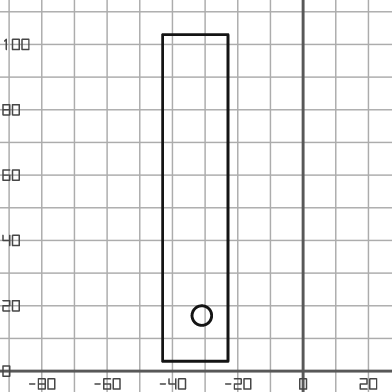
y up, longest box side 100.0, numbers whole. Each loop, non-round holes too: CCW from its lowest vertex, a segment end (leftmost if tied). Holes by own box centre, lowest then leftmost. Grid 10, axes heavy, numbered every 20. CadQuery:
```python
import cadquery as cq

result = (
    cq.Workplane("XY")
    .moveTo(-43.0, 3.0)
    .lineTo(-23.0, 3.0)
    .lineTo(-23.0, 103.0)
    .lineTo(-43.0, 103.0)
    .close()
    .moveTo(-31.0, 17.0)
    .circle(3.0)
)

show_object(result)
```